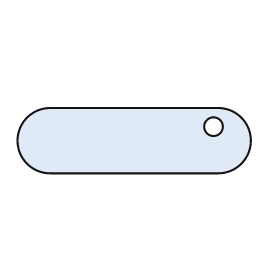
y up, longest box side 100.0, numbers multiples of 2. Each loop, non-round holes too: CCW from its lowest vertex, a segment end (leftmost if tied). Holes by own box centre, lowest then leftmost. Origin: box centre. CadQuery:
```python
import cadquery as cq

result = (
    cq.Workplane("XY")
    .moveTo(-36.0, -14.0)
    .lineTo(36.0, -14.0)
    .threePointArc((50.0, 0.0), (36.0, 14.0))
    .lineTo(-36.0, 14.0)
    .threePointArc((-50.0, 0.0), (-36.0, -14.0))
    .close()
    .moveTo(34.0, 6.0)
    .circle(4.0)
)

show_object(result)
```